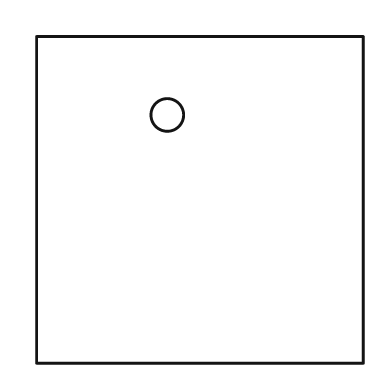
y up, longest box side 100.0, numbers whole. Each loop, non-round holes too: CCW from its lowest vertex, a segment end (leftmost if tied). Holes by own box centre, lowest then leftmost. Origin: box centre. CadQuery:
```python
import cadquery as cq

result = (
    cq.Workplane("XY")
    .moveTo(-50.0, -50.0)
    .lineTo(50.0, -50.0)
    .lineTo(50.0, 50.0)
    .lineTo(-50.0, 50.0)
    .close()
    .moveTo(-10.0, 26.0)
    .circle(5.0)
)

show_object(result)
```